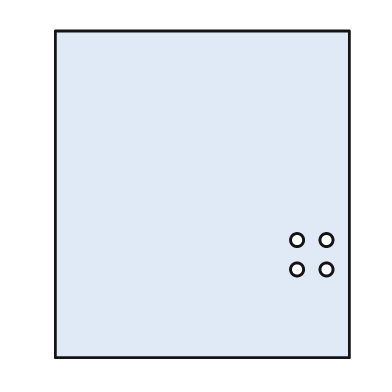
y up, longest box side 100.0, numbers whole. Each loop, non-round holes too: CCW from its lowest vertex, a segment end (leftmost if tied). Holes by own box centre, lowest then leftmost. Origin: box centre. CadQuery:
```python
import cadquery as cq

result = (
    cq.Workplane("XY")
    .moveTo(-45.0, -50.0)
    .lineTo(45.0, -50.0)
    .lineTo(45.0, 50.0)
    .lineTo(-45.0, 50.0)
    .close()
    .moveTo(29.0, -23.0)
    .circle(2.0)
    .moveTo(38.0, -23.0)
    .circle(2.0)
    .moveTo(29.0, -14.0)
    .circle(2.0)
    .moveTo(38.0, -14.0)
    .circle(2.0)
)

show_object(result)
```